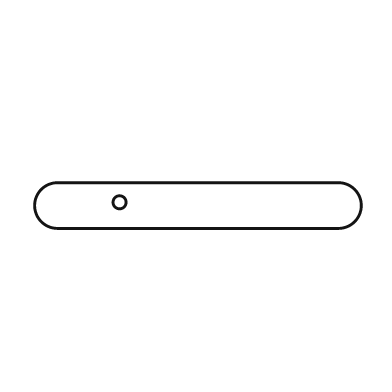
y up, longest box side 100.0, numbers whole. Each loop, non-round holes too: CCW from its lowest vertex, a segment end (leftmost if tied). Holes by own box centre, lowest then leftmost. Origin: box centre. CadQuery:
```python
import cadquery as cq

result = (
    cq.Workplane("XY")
    .moveTo(-43.0, -7.0)
    .lineTo(43.0, -7.0)
    .threePointArc((50.0, 0.0), (43.0, 7.0))
    .lineTo(-43.0, 7.0)
    .threePointArc((-50.0, 0.0), (-43.0, -7.0))
    .close()
    .moveTo(-24.0, 1.0)
    .circle(2.0)
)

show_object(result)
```